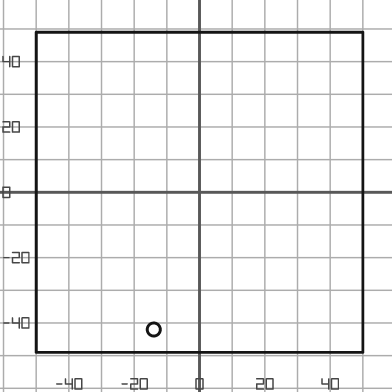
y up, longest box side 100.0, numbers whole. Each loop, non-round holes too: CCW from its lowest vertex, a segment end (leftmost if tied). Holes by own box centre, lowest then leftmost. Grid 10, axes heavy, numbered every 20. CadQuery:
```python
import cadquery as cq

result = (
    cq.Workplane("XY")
    .moveTo(-50.0, -49.0)
    .lineTo(50.0, -49.0)
    .lineTo(50.0, 49.0)
    .lineTo(-50.0, 49.0)
    .close()
    .moveTo(-14.0, -42.0)
    .circle(2.0)
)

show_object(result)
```